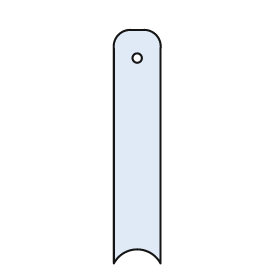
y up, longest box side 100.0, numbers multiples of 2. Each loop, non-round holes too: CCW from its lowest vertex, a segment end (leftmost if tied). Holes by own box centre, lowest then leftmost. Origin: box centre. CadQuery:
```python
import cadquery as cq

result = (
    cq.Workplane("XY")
    .moveTo(-10.0, -50.0)
    .threePointArc((0.0, -44.0), (10.0, -50.0))
    .lineTo(10.0, 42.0)
    .threePointArc((8.0, 48.0), (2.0, 50.0))
    .lineTo(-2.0, 50.0)
    .threePointArc((-8.0, 48.0), (-10.0, 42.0))
    .close()
    .moveTo(0.0, 38.0)
    .circle(2.0)
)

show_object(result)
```